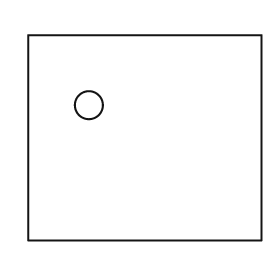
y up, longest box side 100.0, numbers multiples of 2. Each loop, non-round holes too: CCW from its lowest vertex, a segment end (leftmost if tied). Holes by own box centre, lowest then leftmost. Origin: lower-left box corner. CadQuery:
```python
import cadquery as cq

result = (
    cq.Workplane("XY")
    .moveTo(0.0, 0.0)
    .lineTo(100.0, 0.0)
    .lineTo(100.0, 88.0)
    .lineTo(0.0, 88.0)
    .close()
    .moveTo(26.0, 58.0)
    .circle(6.0)
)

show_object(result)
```